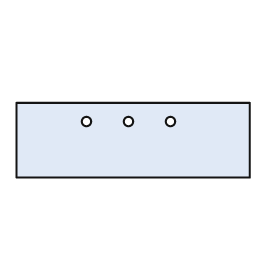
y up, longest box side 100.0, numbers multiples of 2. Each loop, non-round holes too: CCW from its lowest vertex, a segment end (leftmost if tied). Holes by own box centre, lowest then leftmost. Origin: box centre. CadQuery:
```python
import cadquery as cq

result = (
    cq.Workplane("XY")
    .moveTo(-50.0, -16.0)
    .lineTo(50.0, -16.0)
    .lineTo(50.0, 16.0)
    .lineTo(-50.0, 16.0)
    .close()
    .moveTo(-20.0, 8.0)
    .circle(2.0)
    .moveTo(-2.0, 8.0)
    .circle(2.0)
    .moveTo(16.0, 8.0)
    .circle(2.0)
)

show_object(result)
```